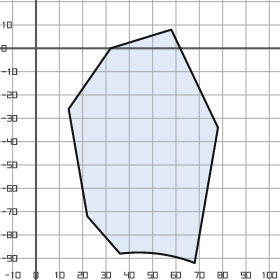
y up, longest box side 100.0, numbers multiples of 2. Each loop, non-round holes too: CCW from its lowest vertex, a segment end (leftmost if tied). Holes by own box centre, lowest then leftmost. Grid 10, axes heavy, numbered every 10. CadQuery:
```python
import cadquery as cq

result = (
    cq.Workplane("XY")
    .moveTo(68.0, -92.0)
    .lineTo(78.0, -34.0)
    .lineTo(58.0, 8.0)
    .lineTo(32.0, 0.0)
    .lineTo(14.0, -26.0)
    .lineTo(22.0, -72.0)
    .lineTo(36.0, -88.0)
    .threePointArc((52.0, -88.0), (68.0, -92.0))
    .close()
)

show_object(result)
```